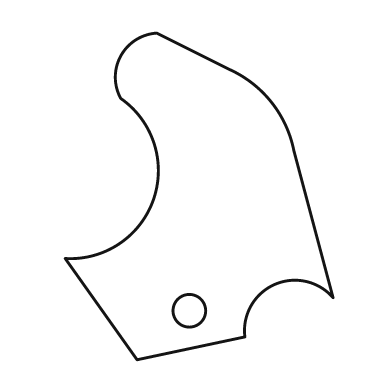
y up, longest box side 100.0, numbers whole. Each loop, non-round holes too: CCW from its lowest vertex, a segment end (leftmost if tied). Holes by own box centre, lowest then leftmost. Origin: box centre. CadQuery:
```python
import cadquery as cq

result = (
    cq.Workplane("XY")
    .moveTo(-19.0, -50.0)
    .lineTo(14.0, -43.0)
    .threePointArc((23.0, -27.0), (41.0, -31.0))
    .lineTo(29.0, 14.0)
    .threePointArc((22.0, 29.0), (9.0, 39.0))
    .lineTo(-13.0, 50.0)
    .threePointArc((-24.0, 43.0), (-24.0, 30.0))
    .threePointArc((-14.0, -1.0), (-41.0, -19.0))
    .close()
    .moveTo(-3.0, -35.0)
    .circle(5.0)
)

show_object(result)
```